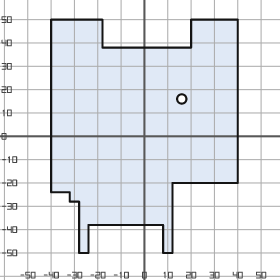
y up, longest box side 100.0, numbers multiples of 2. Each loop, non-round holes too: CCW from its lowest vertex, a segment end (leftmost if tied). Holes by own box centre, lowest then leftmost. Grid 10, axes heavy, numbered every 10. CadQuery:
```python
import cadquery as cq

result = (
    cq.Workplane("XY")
    .moveTo(-28.0, -50.0)
    .lineTo(-24.0, -50.0)
    .lineTo(-24.0, -38.0)
    .lineTo(8.0, -38.0)
    .lineTo(8.0, -50.0)
    .lineTo(12.0, -50.0)
    .lineTo(12.0, -20.0)
    .lineTo(40.0, -20.0)
    .lineTo(40.0, 50.0)
    .lineTo(20.0, 50.0)
    .lineTo(20.0, 38.0)
    .lineTo(-18.0, 38.0)
    .lineTo(-18.0, 50.0)
    .lineTo(-40.0, 50.0)
    .lineTo(-40.0, -24.0)
    .lineTo(-32.0, -24.0)
    .lineTo(-32.0, -28.0)
    .lineTo(-28.0, -28.0)
    .close()
    .moveTo(16.0, 16.0)
    .circle(2.0)
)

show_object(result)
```